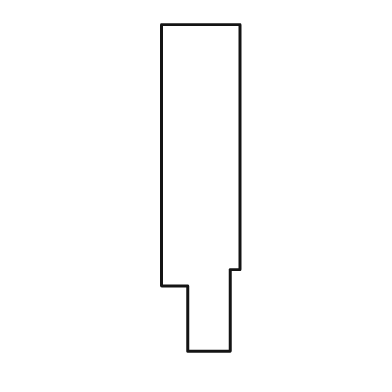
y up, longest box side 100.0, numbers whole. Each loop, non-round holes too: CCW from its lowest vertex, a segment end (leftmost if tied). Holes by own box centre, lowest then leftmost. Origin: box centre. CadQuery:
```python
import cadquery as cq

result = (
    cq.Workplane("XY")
    .moveTo(-4.0, -50.0)
    .lineTo(9.0, -50.0)
    .lineTo(9.0, -25.0)
    .lineTo(12.0, -25.0)
    .lineTo(12.0, 50.0)
    .lineTo(-12.0, 50.0)
    .lineTo(-12.0, -30.0)
    .lineTo(-4.0, -30.0)
    .close()
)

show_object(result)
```